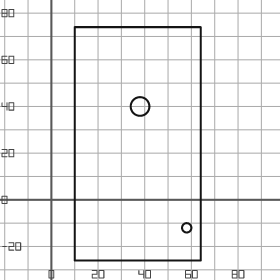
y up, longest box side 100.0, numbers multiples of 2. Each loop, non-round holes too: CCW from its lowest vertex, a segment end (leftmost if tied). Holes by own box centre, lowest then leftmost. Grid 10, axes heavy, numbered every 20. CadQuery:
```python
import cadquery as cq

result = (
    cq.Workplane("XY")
    .moveTo(10.0, -26.0)
    .lineTo(64.0, -26.0)
    .lineTo(64.0, 74.0)
    .lineTo(10.0, 74.0)
    .close()
    .moveTo(58.0, -12.0)
    .circle(2.0)
    .moveTo(38.0, 40.0)
    .circle(4.0)
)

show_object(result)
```